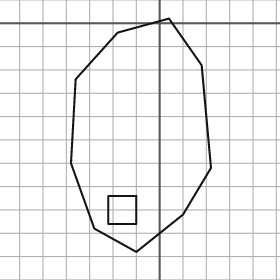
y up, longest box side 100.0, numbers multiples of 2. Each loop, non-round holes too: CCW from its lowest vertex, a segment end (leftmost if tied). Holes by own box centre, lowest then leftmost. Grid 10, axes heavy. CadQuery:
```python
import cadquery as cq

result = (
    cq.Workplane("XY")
    .moveTo(-10.0, -98.0)
    .lineTo(10.0, -82.0)
    .lineTo(22.0, -62.0)
    .lineTo(18.0, -18.0)
    .lineTo(4.0, 2.0)
    .lineTo(-18.0, -4.0)
    .lineTo(-36.0, -24.0)
    .lineTo(-38.0, -60.0)
    .lineTo(-28.0, -88.0)
    .close()
    .moveTo(-22.0, -86.0)
    .lineTo(-10.0, -86.0)
    .lineTo(-10.0, -74.0)
    .lineTo(-22.0, -74.0)
    .close()
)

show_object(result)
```